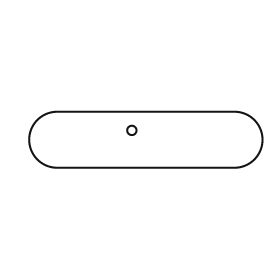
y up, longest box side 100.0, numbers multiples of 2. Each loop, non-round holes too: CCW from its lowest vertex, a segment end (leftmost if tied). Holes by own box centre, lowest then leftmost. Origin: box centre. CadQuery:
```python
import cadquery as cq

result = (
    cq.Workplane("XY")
    .moveTo(-38.0, -12.0)
    .lineTo(38.0, -12.0)
    .threePointArc((50.0, 0.0), (38.0, 12.0))
    .lineTo(-38.0, 12.0)
    .threePointArc((-50.0, 0.0), (-38.0, -12.0))
    .close()
    .moveTo(-6.0, 4.0)
    .circle(2.0)
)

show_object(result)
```